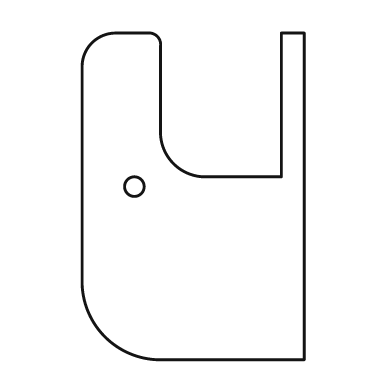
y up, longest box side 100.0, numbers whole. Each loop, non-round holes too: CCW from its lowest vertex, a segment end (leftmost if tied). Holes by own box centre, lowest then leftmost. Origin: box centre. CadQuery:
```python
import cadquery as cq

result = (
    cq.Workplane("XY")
    .moveTo(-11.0, -50.0)
    .lineTo(34.0, -50.0)
    .lineTo(34.0, 50.0)
    .lineTo(27.0, 50.0)
    .lineTo(27.0, 6.0)
    .lineTo(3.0, 6.0)
    .threePointArc((-6.0, 10.0), (-10.0, 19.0))
    .lineTo(-10.0, 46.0)
    .threePointArc((-11.0, 49.0), (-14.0, 50.0))
    .lineTo(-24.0, 50.0)
    .threePointArc((-31.0, 47.0), (-34.0, 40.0))
    .lineTo(-34.0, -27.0)
    .threePointArc((-27.0, -43.0), (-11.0, -50.0))
    .close()
    .moveTo(-18.0, 3.0)
    .circle(3.0)
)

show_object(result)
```